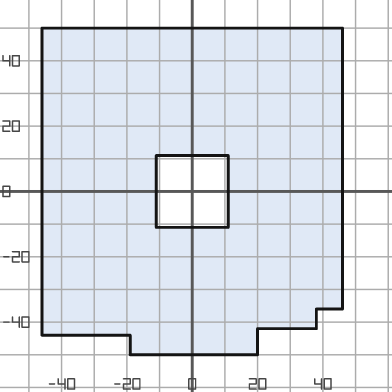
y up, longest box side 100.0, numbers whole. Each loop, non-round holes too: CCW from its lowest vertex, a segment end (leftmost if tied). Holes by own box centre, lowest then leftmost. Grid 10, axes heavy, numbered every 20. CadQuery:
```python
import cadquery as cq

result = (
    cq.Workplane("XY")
    .moveTo(-19.0, -50.0)
    .lineTo(20.0, -50.0)
    .lineTo(20.0, -42.0)
    .lineTo(38.0, -42.0)
    .lineTo(38.0, -36.0)
    .lineTo(46.0, -36.0)
    .lineTo(46.0, 50.0)
    .lineTo(-46.0, 50.0)
    .lineTo(-46.0, -44.0)
    .lineTo(-19.0, -44.0)
    .close()
    .moveTo(-11.0, -11.0)
    .lineTo(11.0, -11.0)
    .lineTo(11.0, 11.0)
    .lineTo(-11.0, 11.0)
    .close()
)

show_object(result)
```